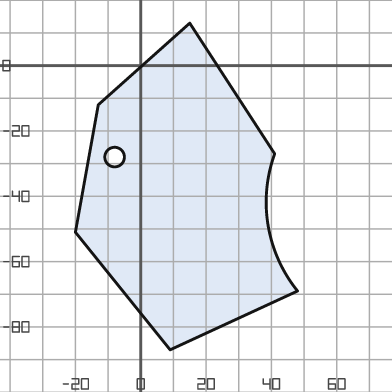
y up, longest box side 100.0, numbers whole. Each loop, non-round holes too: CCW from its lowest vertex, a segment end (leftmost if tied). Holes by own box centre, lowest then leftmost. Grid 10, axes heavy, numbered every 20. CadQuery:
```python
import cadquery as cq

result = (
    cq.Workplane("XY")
    .moveTo(9.0, -87.0)
    .lineTo(48.0, -69.0)
    .threePointArc((39.0, -49.0), (41.0, -27.0))
    .lineTo(15.0, 13.0)
    .lineTo(-13.0, -12.0)
    .lineTo(-20.0, -51.0)
    .close()
    .moveTo(-8.0, -28.0)
    .circle(3.0)
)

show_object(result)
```